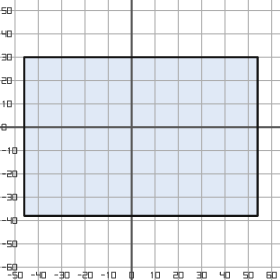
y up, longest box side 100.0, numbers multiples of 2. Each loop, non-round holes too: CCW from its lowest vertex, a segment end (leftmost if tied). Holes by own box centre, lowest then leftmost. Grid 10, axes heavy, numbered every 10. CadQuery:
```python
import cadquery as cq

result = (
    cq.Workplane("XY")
    .moveTo(-46.0, -38.0)
    .lineTo(54.0, -38.0)
    .lineTo(54.0, 30.0)
    .lineTo(-46.0, 30.0)
    .close()
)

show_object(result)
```